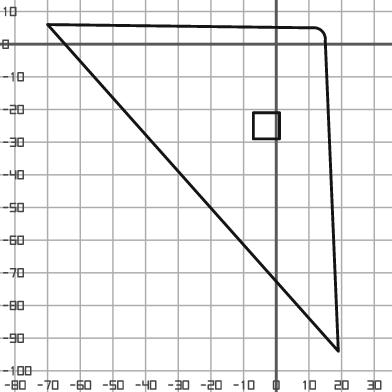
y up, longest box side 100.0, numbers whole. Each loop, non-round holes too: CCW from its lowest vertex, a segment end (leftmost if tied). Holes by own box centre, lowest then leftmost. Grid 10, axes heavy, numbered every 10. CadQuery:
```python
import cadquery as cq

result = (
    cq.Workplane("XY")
    .moveTo(19.0, -94.0)
    .lineTo(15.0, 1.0)
    .threePointArc((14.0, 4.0), (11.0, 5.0))
    .lineTo(-70.0, 6.0)
    .close()
    .moveTo(-7.0, -29.0)
    .lineTo(1.0, -29.0)
    .lineTo(1.0, -21.0)
    .lineTo(-7.0, -21.0)
    .close()
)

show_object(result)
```